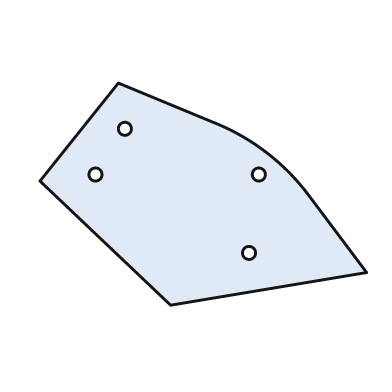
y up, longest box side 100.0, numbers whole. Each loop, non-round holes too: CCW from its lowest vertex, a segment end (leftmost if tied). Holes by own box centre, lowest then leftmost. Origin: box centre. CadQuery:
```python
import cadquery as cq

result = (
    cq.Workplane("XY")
    .moveTo(-10.0, -34.0)
    .lineTo(50.0, -24.0)
    .lineTo(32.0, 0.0)
    .threePointArc((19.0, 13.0), (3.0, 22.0))
    .lineTo(-26.0, 34.0)
    .lineTo(-50.0, 4.0)
    .close()
    .moveTo(14.0, -18.0)
    .circle(2.0)
    .moveTo(-33.0, 6.0)
    .circle(2.0)
    .moveTo(17.0, 6.0)
    .circle(2.0)
    .moveTo(-24.0, 20.0)
    .circle(2.0)
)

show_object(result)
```